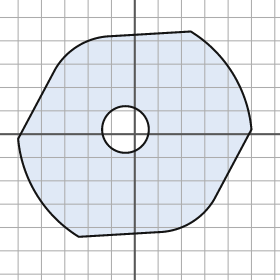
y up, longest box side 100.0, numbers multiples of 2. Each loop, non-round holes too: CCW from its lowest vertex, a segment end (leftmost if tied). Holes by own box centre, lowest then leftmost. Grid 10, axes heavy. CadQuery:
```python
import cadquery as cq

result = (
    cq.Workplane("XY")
    .moveTo(-24.0, -44.0)
    .lineTo(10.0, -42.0)
    .threePointArc((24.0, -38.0), (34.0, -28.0))
    .lineTo(50.0, 2.0)
    .threePointArc((42.0, 26.0), (24.0, 44.0))
    .lineTo(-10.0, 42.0)
    .threePointArc((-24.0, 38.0), (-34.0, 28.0))
    .lineTo(-50.0, -2.0)
    .threePointArc((-42.0, -26.0), (-24.0, -44.0))
    .close()
    .moveTo(-4.0, 2.0)
    .circle(10.0)
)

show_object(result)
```